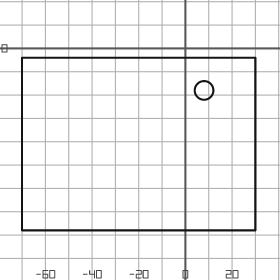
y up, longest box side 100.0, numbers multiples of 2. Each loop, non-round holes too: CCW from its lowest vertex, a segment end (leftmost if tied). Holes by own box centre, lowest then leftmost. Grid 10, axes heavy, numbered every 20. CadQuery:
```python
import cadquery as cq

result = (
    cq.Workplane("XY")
    .moveTo(-70.0, -78.0)
    .lineTo(30.0, -78.0)
    .lineTo(30.0, -4.0)
    .lineTo(-70.0, -4.0)
    .close()
    .moveTo(8.0, -18.0)
    .circle(4.0)
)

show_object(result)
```